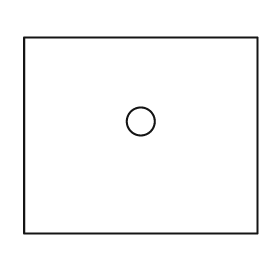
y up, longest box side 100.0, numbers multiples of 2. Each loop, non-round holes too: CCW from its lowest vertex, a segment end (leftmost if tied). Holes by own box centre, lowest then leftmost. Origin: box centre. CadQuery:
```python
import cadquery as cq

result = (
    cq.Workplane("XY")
    .moveTo(-50.0, -42.0)
    .lineTo(50.0, -42.0)
    .lineTo(50.0, 42.0)
    .lineTo(-50.0, 42.0)
    .close()
    .moveTo(0.0, 6.0)
    .circle(6.0)
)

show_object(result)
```